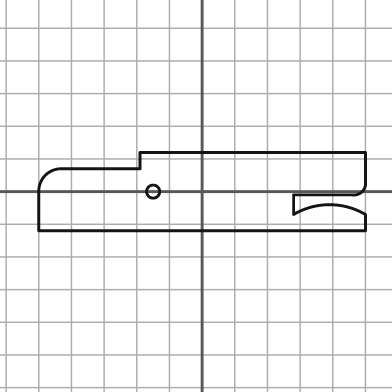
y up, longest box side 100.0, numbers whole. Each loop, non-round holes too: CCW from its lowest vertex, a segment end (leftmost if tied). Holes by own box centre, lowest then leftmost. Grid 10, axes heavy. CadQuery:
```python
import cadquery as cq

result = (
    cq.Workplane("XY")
    .moveTo(-50.0, -12.0)
    .lineTo(50.0, -12.0)
    .lineTo(50.0, -7.0)
    .threePointArc((39.0, -4.0), (28.0, -7.0))
    .lineTo(28.0, -1.0)
    .lineTo(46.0, -1.0)
    .threePointArc((49.0, 0.0), (50.0, 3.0))
    .lineTo(50.0, 12.0)
    .lineTo(-19.0, 12.0)
    .lineTo(-19.0, 7.0)
    .lineTo(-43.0, 7.0)
    .threePointArc((-48.0, 5.0), (-50.0, 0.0))
    .close()
    .moveTo(-15.0, 0.0)
    .circle(2.0)
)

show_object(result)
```